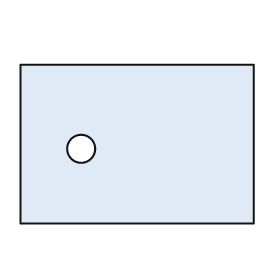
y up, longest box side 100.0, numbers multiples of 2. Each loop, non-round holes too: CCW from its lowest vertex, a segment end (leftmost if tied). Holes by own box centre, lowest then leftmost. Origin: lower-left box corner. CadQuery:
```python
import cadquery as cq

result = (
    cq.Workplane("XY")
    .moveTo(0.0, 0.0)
    .lineTo(100.0, 0.0)
    .lineTo(100.0, 68.0)
    .lineTo(0.0, 68.0)
    .close()
    .moveTo(26.0, 32.0)
    .circle(6.0)
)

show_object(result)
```